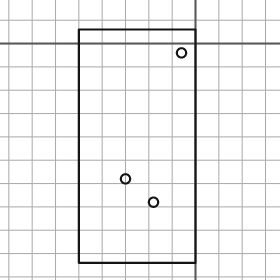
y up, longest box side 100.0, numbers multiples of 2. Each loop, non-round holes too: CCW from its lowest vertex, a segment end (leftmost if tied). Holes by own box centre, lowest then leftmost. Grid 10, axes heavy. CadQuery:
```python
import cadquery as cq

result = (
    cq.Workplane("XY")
    .moveTo(-50.0, -94.0)
    .lineTo(0.0, -94.0)
    .lineTo(0.0, 6.0)
    .lineTo(-50.0, 6.0)
    .close()
    .moveTo(-18.0, -68.0)
    .circle(2.0)
    .moveTo(-30.0, -58.0)
    .circle(2.0)
    .moveTo(-6.0, -4.0)
    .circle(2.0)
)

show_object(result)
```